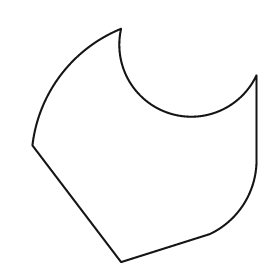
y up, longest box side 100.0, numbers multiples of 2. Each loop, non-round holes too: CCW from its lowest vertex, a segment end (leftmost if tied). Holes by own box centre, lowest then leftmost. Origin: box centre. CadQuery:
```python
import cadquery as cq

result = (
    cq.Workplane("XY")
    .moveTo(-10.0, -50.0)
    .lineTo(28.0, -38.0)
    .threePointArc((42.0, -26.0), (48.0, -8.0))
    .lineTo(48.0, 30.0)
    .threePointArc((10.0, 14.0), (-10.0, 50.0))
    .threePointArc((-36.0, 30.0), (-48.0, 0.0))
    .close()
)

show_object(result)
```